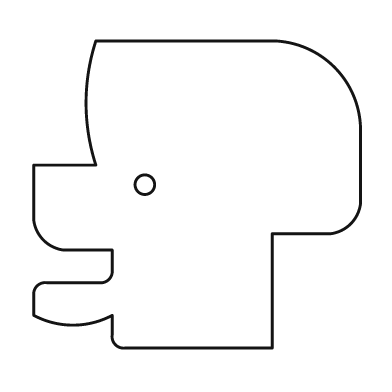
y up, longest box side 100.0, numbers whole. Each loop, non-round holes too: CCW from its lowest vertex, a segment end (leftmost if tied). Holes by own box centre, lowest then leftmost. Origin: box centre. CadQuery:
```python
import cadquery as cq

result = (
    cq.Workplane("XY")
    .moveTo(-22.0, -47.0)
    .lineTo(23.0, -47.0)
    .lineTo(23.0, -12.0)
    .lineTo(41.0, -12.0)
    .threePointArc((47.0, -9.0), (50.0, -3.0))
    .lineTo(50.0, 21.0)
    .threePointArc((42.0, 39.0), (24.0, 47.0))
    .lineTo(-31.0, 47.0)
    .threePointArc((-34.0, 28.0), (-31.0, 9.0))
    .lineTo(-50.0, 9.0)
    .lineTo(-50.0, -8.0)
    .threePointArc((-47.0, -14.0), (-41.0, -17.0))
    .lineTo(-26.0, -17.0)
    .lineTo(-26.0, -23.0)
    .threePointArc((-27.0, -26.0), (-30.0, -27.0))
    .lineTo(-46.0, -27.0)
    .threePointArc((-49.0, -28.0), (-50.0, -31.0))
    .lineTo(-50.0, -37.0)
    .threePointArc((-38.0, -40.0), (-26.0, -37.0))
    .lineTo(-26.0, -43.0)
    .threePointArc((-25.0, -46.0), (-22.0, -47.0))
    .close()
    .moveTo(-16.0, 3.0)
    .circle(3.0)
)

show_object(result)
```